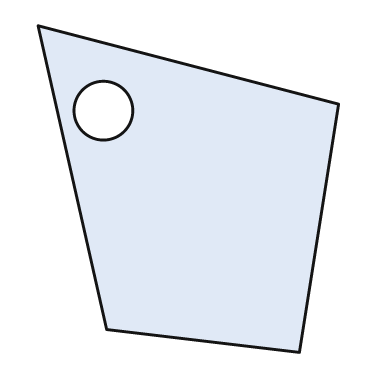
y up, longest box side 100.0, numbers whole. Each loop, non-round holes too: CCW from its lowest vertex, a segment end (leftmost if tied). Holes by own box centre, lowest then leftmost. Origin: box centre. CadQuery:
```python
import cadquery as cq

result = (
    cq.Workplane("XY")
    .moveTo(34.0, -50.0)
    .lineTo(46.0, 26.0)
    .lineTo(-46.0, 50.0)
    .lineTo(-25.0, -43.0)
    .close()
    .moveTo(-26.0, 24.0)
    .circle(9.0)
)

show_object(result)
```